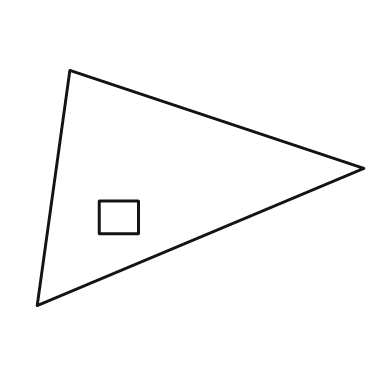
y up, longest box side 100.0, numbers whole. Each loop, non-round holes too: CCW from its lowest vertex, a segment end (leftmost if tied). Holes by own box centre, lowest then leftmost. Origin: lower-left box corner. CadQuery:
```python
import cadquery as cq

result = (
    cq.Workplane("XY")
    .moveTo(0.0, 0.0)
    .lineTo(100.0, 42.0)
    .lineTo(10.0, 72.0)
    .close()
    .moveTo(19.0, 22.0)
    .lineTo(31.0, 22.0)
    .lineTo(31.0, 32.0)
    .lineTo(19.0, 32.0)
    .close()
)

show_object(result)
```